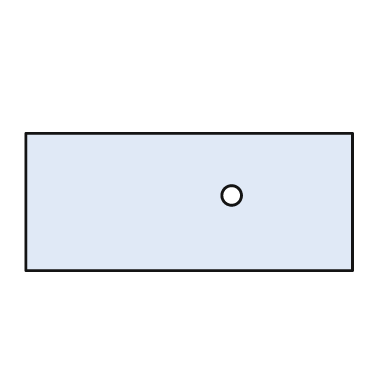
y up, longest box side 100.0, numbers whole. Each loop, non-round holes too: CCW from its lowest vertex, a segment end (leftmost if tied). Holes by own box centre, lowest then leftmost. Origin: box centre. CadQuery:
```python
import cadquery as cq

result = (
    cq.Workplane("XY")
    .moveTo(-50.0, -21.0)
    .lineTo(50.0, -21.0)
    .lineTo(50.0, 21.0)
    .lineTo(-50.0, 21.0)
    .close()
    .moveTo(13.0, 2.0)
    .circle(3.0)
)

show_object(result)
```